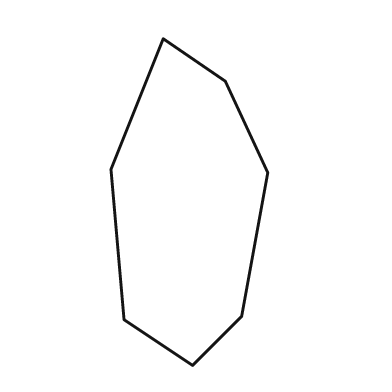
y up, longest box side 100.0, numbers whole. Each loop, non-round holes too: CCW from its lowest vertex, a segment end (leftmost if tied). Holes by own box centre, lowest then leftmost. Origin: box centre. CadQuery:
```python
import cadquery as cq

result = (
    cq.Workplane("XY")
    .moveTo(1.0, -50.0)
    .lineTo(16.0, -35.0)
    .lineTo(24.0, 9.0)
    .lineTo(11.0, 37.0)
    .lineTo(-8.0, 50.0)
    .lineTo(-24.0, 10.0)
    .lineTo(-20.0, -36.0)
    .close()
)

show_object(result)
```